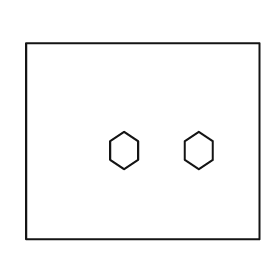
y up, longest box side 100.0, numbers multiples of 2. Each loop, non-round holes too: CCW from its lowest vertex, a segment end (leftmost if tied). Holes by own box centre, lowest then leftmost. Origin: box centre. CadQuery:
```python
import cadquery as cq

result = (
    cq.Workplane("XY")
    .moveTo(-50.0, -42.0)
    .lineTo(50.0, -42.0)
    .lineTo(50.0, 42.0)
    .lineTo(-50.0, 42.0)
    .close()
    .moveTo(-8.0, -12.0)
    .lineTo(-2.0, -8.0)
    .lineTo(-2.0, 0.0)
    .lineTo(-8.0, 4.0)
    .lineTo(-14.0, 0.0)
    .lineTo(-14.0, -8.0)
    .close()
    .moveTo(24.0, -12.0)
    .lineTo(30.0, -8.0)
    .lineTo(30.0, 0.0)
    .lineTo(24.0, 4.0)
    .lineTo(18.0, 0.0)
    .lineTo(18.0, -8.0)
    .close()
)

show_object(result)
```